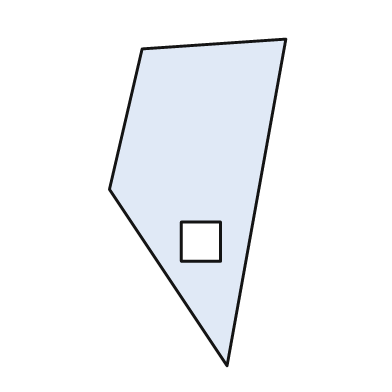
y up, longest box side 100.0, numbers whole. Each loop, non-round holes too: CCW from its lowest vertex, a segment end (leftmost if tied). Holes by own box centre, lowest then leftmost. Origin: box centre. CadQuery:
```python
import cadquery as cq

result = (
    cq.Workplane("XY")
    .moveTo(9.0, -50.0)
    .lineTo(27.0, 50.0)
    .lineTo(-17.0, 47.0)
    .lineTo(-27.0, 4.0)
    .close()
    .moveTo(-5.0, -18.0)
    .lineTo(7.0, -18.0)
    .lineTo(7.0, -6.0)
    .lineTo(-5.0, -6.0)
    .close()
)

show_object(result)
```